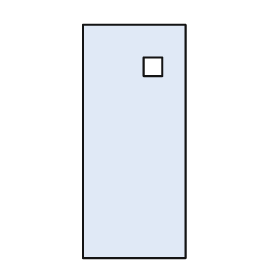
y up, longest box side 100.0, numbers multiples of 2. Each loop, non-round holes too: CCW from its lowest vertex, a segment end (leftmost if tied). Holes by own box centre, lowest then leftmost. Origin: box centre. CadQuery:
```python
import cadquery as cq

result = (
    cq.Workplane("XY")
    .moveTo(-22.0, -50.0)
    .lineTo(22.0, -50.0)
    .lineTo(22.0, 50.0)
    .lineTo(-22.0, 50.0)
    .close()
    .moveTo(4.0, 28.0)
    .lineTo(12.0, 28.0)
    .lineTo(12.0, 36.0)
    .lineTo(4.0, 36.0)
    .close()
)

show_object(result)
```